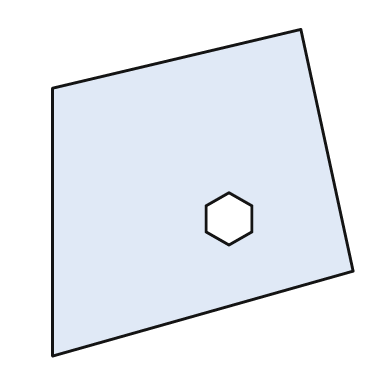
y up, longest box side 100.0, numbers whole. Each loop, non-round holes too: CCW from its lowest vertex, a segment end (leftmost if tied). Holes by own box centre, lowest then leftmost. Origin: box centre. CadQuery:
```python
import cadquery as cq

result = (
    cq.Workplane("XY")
    .moveTo(-46.0, -50.0)
    .lineTo(46.0, -24.0)
    .lineTo(30.0, 50.0)
    .lineTo(-46.0, 32.0)
    .close()
    .moveTo(8.0, -16.0)
    .lineTo(15.0, -12.0)
    .lineTo(15.0, -4.0)
    .lineTo(8.0, 0.0)
    .lineTo(1.0, -4.0)
    .lineTo(1.0, -12.0)
    .close()
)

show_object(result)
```